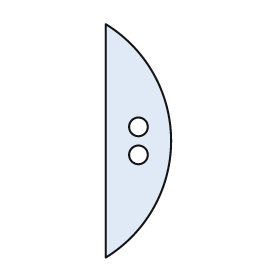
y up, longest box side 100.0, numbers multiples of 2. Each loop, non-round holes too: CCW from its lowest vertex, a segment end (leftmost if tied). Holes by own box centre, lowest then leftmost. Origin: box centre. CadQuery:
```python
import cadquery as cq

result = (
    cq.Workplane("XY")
    .moveTo(-14.0, -50.0)
    .threePointArc((14.0, 0.0), (-14.0, 50.0))
    .close()
    .moveTo(0.0, -6.0)
    .circle(4.0)
    .moveTo(0.0, 6.0)
    .circle(4.0)
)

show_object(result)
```